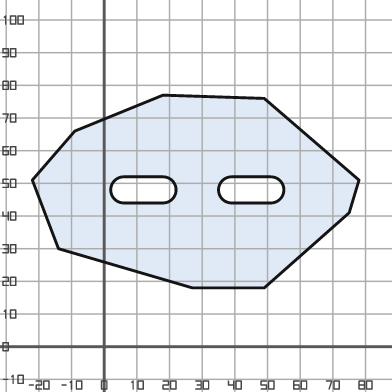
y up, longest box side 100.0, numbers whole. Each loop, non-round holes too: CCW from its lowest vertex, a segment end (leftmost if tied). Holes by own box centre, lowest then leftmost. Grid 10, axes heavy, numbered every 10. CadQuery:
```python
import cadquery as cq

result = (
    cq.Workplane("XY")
    .moveTo(27.0, 18.0)
    .lineTo(49.0, 18.0)
    .lineTo(75.0, 41.0)
    .lineTo(78.0, 51.0)
    .lineTo(49.0, 76.0)
    .lineTo(18.0, 77.0)
    .lineTo(-9.0, 66.0)
    .lineTo(-22.0, 51.0)
    .lineTo(-14.0, 30.0)
    .close()
    .moveTo(6.0, 44.0)
    .lineTo(18.0, 44.0)
    .threePointArc((22.0, 48.0), (18.0, 52.0))
    .lineTo(6.0, 52.0)
    .threePointArc((2.0, 48.0), (6.0, 44.0))
    .close()
    .moveTo(39.0, 44.0)
    .lineTo(51.0, 44.0)
    .threePointArc((55.0, 48.0), (51.0, 52.0))
    .lineTo(39.0, 52.0)
    .threePointArc((35.0, 48.0), (39.0, 44.0))
    .close()
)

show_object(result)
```